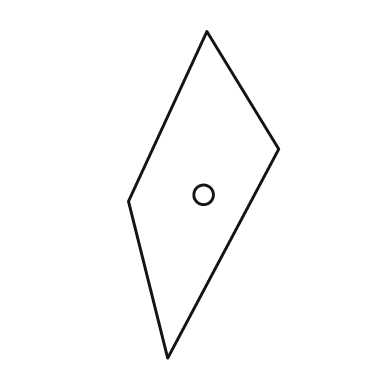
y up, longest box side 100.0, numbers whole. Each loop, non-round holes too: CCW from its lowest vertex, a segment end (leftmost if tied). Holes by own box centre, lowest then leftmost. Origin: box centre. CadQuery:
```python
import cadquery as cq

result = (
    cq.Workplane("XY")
    .moveTo(-11.0, -50.0)
    .lineTo(23.0, 14.0)
    .lineTo(1.0, 50.0)
    .lineTo(-23.0, -2.0)
    .close()
    .moveTo(0.0, 0.0)
    .circle(3.0)
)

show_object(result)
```